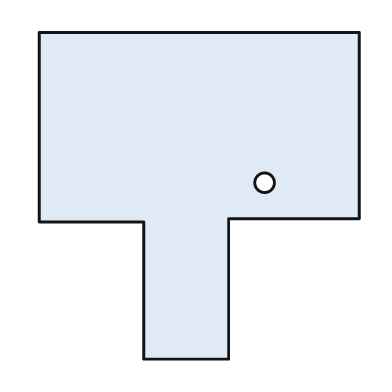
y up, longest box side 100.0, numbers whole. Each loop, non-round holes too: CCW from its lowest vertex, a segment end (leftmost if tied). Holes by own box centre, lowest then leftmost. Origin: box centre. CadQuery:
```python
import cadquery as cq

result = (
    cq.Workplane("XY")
    .moveTo(-17.0, -50.0)
    .lineTo(9.0, -50.0)
    .lineTo(9.0, -7.0)
    .lineTo(49.0, -7.0)
    .lineTo(49.0, 50.0)
    .lineTo(-49.0, 50.0)
    .lineTo(-49.0, -8.0)
    .lineTo(-17.0, -8.0)
    .close()
    .moveTo(20.0, 4.0)
    .circle(3.0)
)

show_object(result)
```